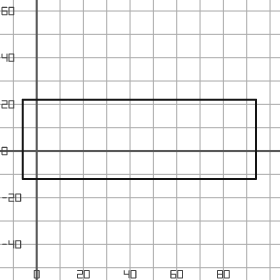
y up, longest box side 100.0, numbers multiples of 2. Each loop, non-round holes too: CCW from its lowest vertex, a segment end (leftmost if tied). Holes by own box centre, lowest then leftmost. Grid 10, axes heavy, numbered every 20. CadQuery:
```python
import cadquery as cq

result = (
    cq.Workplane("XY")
    .moveTo(-6.0, -12.0)
    .lineTo(94.0, -12.0)
    .lineTo(94.0, 22.0)
    .lineTo(-6.0, 22.0)
    .close()
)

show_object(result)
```